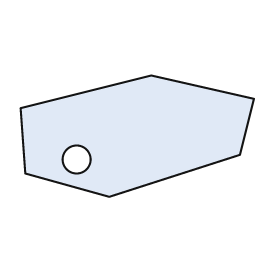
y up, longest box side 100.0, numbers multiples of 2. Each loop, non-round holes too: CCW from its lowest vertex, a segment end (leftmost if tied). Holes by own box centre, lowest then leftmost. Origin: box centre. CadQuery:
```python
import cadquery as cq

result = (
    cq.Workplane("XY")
    .moveTo(-12.0, -26.0)
    .lineTo(44.0, -8.0)
    .lineTo(50.0, 16.0)
    .lineTo(6.0, 26.0)
    .lineTo(-50.0, 12.0)
    .lineTo(-48.0, -16.0)
    .close()
    .moveTo(-26.0, -10.0)
    .circle(6.0)
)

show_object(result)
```